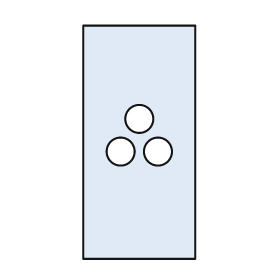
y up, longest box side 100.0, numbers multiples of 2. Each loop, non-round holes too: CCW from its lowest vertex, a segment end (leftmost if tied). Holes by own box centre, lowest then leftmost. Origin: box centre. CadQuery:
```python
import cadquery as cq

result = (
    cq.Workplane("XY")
    .moveTo(-24.0, -50.0)
    .lineTo(24.0, -50.0)
    .lineTo(24.0, 50.0)
    .lineTo(-24.0, 50.0)
    .close()
    .moveTo(-8.0, -4.0)
    .circle(6.0)
    .moveTo(8.0, -4.0)
    .circle(6.0)
    .moveTo(0.0, 10.0)
    .circle(6.0)
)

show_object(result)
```